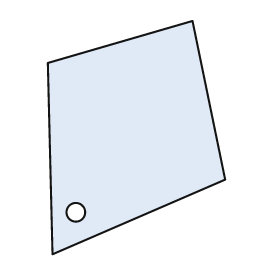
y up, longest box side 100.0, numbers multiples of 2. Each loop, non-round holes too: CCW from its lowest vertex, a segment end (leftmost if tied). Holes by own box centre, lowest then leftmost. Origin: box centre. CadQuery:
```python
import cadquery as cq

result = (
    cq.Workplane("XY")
    .moveTo(-36.0, -50.0)
    .lineTo(38.0, -18.0)
    .lineTo(24.0, 50.0)
    .lineTo(-38.0, 32.0)
    .close()
    .moveTo(-26.0, -32.0)
    .circle(4.0)
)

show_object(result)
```